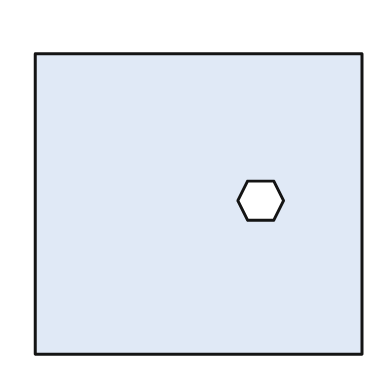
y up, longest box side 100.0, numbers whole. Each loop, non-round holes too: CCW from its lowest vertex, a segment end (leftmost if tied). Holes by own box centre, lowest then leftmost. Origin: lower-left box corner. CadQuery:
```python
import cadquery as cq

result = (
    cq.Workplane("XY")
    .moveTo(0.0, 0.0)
    .lineTo(100.0, 0.0)
    .lineTo(100.0, 92.0)
    .lineTo(0.0, 92.0)
    .close()
    .moveTo(65.0, 41.0)
    .lineTo(73.0, 41.0)
    .lineTo(76.0, 47.0)
    .lineTo(73.0, 53.0)
    .lineTo(65.0, 53.0)
    .lineTo(62.0, 47.0)
    .close()
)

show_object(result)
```